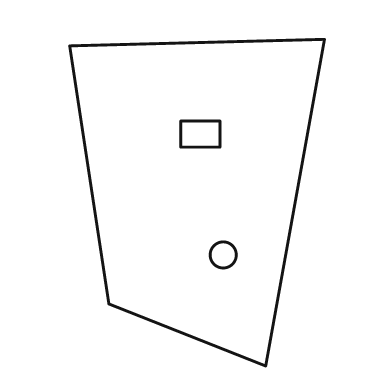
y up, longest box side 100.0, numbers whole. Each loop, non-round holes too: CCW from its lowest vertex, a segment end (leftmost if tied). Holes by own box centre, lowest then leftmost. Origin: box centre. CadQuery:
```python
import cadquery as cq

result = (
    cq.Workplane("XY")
    .moveTo(21.0, -50.0)
    .lineTo(39.0, 50.0)
    .lineTo(-39.0, 48.0)
    .lineTo(-27.0, -31.0)
    .close()
    .moveTo(8.0, -16.0)
    .circle(4.0)
    .moveTo(-5.0, 17.0)
    .lineTo(7.0, 17.0)
    .lineTo(7.0, 25.0)
    .lineTo(-5.0, 25.0)
    .close()
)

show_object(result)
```